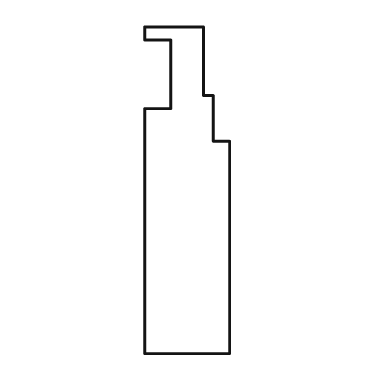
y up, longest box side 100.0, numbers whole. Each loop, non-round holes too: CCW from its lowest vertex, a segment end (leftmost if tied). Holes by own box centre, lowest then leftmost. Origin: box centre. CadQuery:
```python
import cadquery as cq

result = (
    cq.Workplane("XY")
    .moveTo(-13.0, -50.0)
    .lineTo(13.0, -50.0)
    .lineTo(13.0, 15.0)
    .lineTo(8.0, 15.0)
    .lineTo(8.0, 29.0)
    .lineTo(5.0, 29.0)
    .lineTo(5.0, 50.0)
    .lineTo(-13.0, 50.0)
    .lineTo(-13.0, 46.0)
    .lineTo(-5.0, 46.0)
    .lineTo(-5.0, 25.0)
    .lineTo(-13.0, 25.0)
    .close()
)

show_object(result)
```